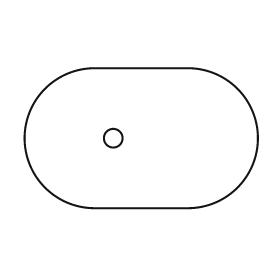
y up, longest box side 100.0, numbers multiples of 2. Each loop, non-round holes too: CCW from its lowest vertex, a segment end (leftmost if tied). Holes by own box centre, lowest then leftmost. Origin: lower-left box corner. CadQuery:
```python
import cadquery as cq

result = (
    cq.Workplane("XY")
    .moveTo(30.0, 0.0)
    .lineTo(70.0, 0.0)
    .threePointArc((100.0, 30.0), (70.0, 60.0))
    .lineTo(30.0, 60.0)
    .threePointArc((0.0, 30.0), (30.0, 0.0))
    .close()
    .moveTo(38.0, 30.0)
    .circle(4.0)
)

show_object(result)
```